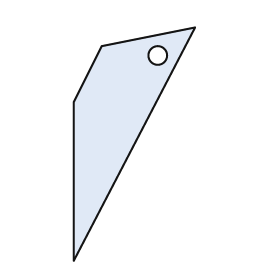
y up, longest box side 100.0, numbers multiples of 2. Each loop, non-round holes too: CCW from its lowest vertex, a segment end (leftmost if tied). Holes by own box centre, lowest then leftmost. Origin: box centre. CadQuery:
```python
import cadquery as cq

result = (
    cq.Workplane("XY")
    .moveTo(-26.0, -50.0)
    .lineTo(26.0, 50.0)
    .lineTo(-14.0, 42.0)
    .lineTo(-26.0, 18.0)
    .close()
    .moveTo(10.0, 38.0)
    .circle(4.0)
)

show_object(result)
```